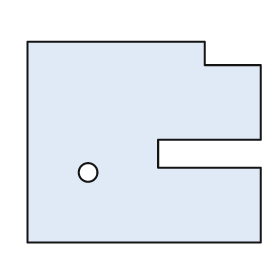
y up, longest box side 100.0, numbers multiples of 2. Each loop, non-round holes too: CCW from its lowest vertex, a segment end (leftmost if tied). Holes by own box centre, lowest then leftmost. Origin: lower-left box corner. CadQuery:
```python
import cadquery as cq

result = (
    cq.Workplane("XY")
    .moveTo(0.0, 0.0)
    .lineTo(100.0, 0.0)
    .lineTo(100.0, 32.0)
    .lineTo(56.0, 32.0)
    .lineTo(56.0, 44.0)
    .lineTo(100.0, 44.0)
    .lineTo(100.0, 76.0)
    .lineTo(76.0, 76.0)
    .lineTo(76.0, 86.0)
    .lineTo(0.0, 86.0)
    .close()
    .moveTo(26.0, 30.0)
    .circle(4.0)
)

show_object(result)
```